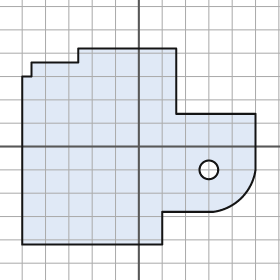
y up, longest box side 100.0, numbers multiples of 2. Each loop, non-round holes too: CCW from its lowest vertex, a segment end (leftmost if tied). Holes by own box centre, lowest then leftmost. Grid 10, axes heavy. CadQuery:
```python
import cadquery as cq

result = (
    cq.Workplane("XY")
    .moveTo(-50.0, -42.0)
    .lineTo(10.0, -42.0)
    .lineTo(10.0, -28.0)
    .lineTo(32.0, -28.0)
    .threePointArc((44.0, -22.0), (50.0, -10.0))
    .lineTo(50.0, 14.0)
    .lineTo(16.0, 14.0)
    .lineTo(16.0, 42.0)
    .lineTo(-26.0, 42.0)
    .lineTo(-26.0, 36.0)
    .lineTo(-46.0, 36.0)
    .lineTo(-46.0, 30.0)
    .lineTo(-50.0, 30.0)
    .close()
    .moveTo(30.0, -10.0)
    .circle(4.0)
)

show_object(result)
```